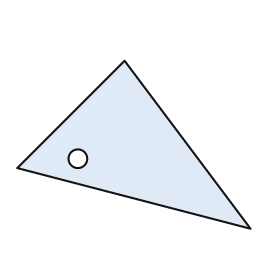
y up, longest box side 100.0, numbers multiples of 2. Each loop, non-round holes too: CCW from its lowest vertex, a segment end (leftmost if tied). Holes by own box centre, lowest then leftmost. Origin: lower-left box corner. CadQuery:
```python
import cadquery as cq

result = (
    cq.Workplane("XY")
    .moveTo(100.0, 0.0)
    .lineTo(46.0, 72.0)
    .lineTo(0.0, 26.0)
    .close()
    .moveTo(26.0, 30.0)
    .circle(4.0)
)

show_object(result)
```